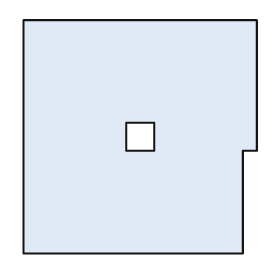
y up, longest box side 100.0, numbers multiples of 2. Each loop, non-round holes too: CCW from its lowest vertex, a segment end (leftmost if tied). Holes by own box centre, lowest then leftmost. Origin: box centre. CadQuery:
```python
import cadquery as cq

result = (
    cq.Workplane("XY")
    .moveTo(-50.0, -50.0)
    .lineTo(44.0, -50.0)
    .lineTo(44.0, -6.0)
    .lineTo(50.0, -6.0)
    .lineTo(50.0, 50.0)
    .lineTo(-50.0, 50.0)
    .close()
    .moveTo(-6.0, -6.0)
    .lineTo(6.0, -6.0)
    .lineTo(6.0, 6.0)
    .lineTo(-6.0, 6.0)
    .close()
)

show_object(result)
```